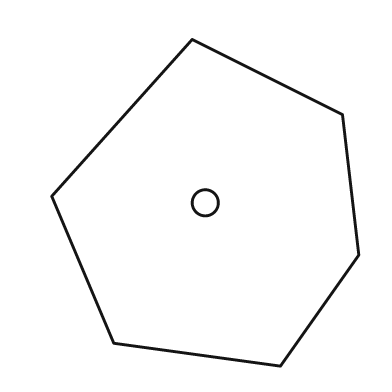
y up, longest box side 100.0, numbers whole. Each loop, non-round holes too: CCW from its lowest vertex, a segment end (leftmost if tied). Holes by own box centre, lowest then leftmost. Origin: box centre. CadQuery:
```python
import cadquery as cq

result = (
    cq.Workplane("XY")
    .moveTo(23.0, -50.0)
    .lineTo(47.0, -16.0)
    .lineTo(42.0, 27.0)
    .lineTo(-4.0, 50.0)
    .lineTo(-47.0, 2.0)
    .lineTo(-28.0, -43.0)
    .close()
    .moveTo(0.0, 0.0)
    .circle(4.0)
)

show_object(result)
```